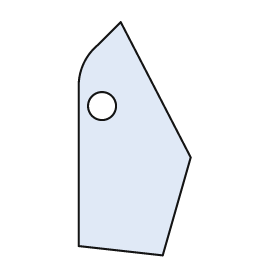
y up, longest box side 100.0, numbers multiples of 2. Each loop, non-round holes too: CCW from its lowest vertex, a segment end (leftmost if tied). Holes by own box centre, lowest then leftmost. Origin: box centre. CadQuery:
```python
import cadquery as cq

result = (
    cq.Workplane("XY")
    .moveTo(12.0, -50.0)
    .lineTo(24.0, -8.0)
    .lineTo(-6.0, 50.0)
    .lineTo(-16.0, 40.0)
    .threePointArc((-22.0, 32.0), (-24.0, 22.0))
    .lineTo(-24.0, -46.0)
    .close()
    .moveTo(-14.0, 14.0)
    .circle(6.0)
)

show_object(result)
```